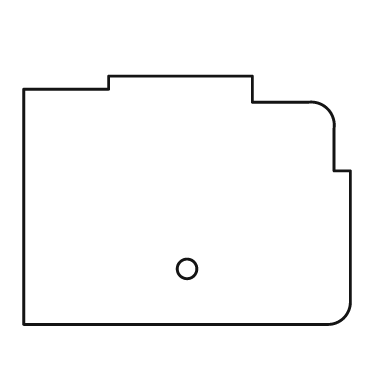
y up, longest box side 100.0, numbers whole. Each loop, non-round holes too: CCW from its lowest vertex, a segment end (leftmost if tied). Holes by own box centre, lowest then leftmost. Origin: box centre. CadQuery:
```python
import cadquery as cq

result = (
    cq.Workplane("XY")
    .moveTo(-50.0, -38.0)
    .lineTo(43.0, -38.0)
    .threePointArc((48.0, -36.0), (50.0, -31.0))
    .lineTo(50.0, 9.0)
    .lineTo(45.0, 9.0)
    .lineTo(45.0, 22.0)
    .threePointArc((43.0, 28.0), (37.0, 30.0))
    .lineTo(20.0, 30.0)
    .lineTo(20.0, 38.0)
    .lineTo(-24.0, 38.0)
    .lineTo(-24.0, 34.0)
    .lineTo(-50.0, 34.0)
    .close()
    .moveTo(0.0, -21.0)
    .circle(3.0)
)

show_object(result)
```